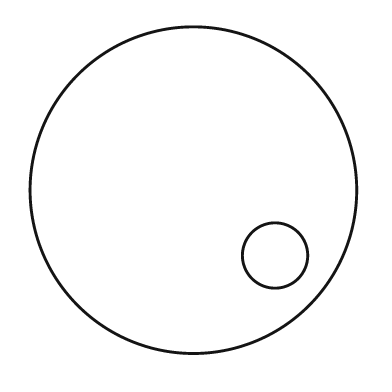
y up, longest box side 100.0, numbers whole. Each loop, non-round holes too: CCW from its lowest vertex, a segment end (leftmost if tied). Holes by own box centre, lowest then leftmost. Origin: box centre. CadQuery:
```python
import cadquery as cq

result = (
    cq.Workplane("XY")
    .moveTo(0.0, 0.0)
    .circle(50.0)
    .moveTo(25.0, -20.0)
    .circle(10.0)
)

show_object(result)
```